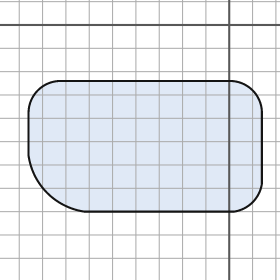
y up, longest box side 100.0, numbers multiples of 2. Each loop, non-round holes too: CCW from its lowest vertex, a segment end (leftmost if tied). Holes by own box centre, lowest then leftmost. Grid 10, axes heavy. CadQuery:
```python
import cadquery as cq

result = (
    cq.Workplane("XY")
    .moveTo(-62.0, -80.0)
    .lineTo(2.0, -80.0)
    .threePointArc((10.0, -76.0), (14.0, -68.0))
    .lineTo(14.0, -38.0)
    .threePointArc((10.0, -28.0), (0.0, -24.0))
    .lineTo(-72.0, -24.0)
    .threePointArc((-82.0, -28.0), (-86.0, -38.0))
    .lineTo(-86.0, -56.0)
    .threePointArc((-78.0, -72.0), (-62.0, -80.0))
    .close()
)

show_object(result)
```